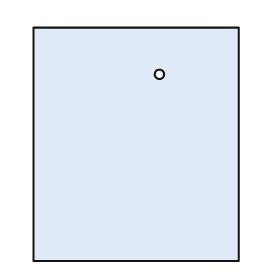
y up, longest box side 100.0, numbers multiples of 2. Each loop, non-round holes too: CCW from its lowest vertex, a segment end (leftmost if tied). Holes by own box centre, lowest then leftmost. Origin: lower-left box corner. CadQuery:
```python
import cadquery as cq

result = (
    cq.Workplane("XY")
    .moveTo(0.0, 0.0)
    .lineTo(88.0, 0.0)
    .lineTo(88.0, 100.0)
    .lineTo(0.0, 100.0)
    .close()
    .moveTo(54.0, 80.0)
    .circle(2.0)
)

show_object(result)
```